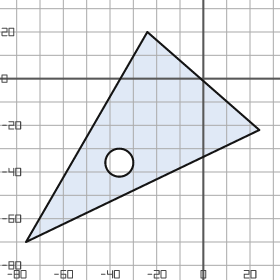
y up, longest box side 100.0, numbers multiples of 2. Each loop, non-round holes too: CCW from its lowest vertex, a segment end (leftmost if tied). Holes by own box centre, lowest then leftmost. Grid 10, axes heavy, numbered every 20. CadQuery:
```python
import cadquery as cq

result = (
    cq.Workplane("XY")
    .moveTo(-76.0, -70.0)
    .lineTo(24.0, -22.0)
    .lineTo(-24.0, 20.0)
    .close()
    .moveTo(-36.0, -36.0)
    .circle(6.0)
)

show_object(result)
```